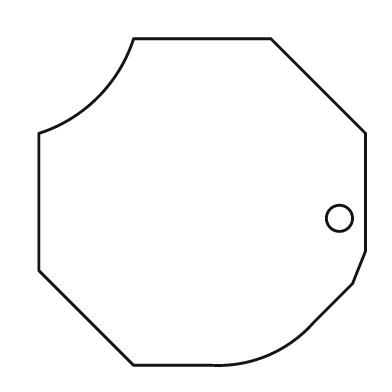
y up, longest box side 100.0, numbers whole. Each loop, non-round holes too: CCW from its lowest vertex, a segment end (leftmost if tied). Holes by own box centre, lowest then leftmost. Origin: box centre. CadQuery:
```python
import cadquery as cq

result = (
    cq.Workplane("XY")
    .moveTo(-21.0, -50.0)
    .lineTo(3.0, -50.0)
    .threePointArc((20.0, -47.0), (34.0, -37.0))
    .lineTo(46.0, -25.0)
    .lineTo(50.0, -15.0)
    .lineTo(50.0, 21.0)
    .lineTo(21.0, 50.0)
    .lineTo(-21.0, 50.0)
    .threePointArc((-32.0, 32.0), (-50.0, 21.0))
    .lineTo(-50.0, -21.0)
    .close()
    .moveTo(42.0, -5.0)
    .circle(4.0)
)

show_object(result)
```